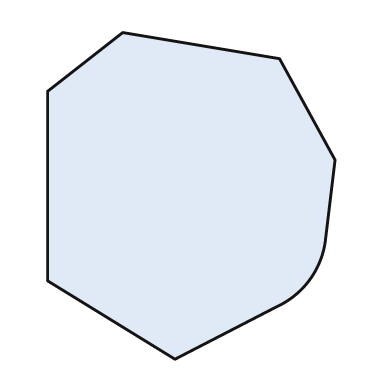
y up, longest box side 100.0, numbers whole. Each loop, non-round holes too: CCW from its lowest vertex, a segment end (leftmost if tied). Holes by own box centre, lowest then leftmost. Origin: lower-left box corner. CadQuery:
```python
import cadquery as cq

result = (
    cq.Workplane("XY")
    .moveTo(39.0, 0.0)
    .lineTo(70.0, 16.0)
    .threePointArc((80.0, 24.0), (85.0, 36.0))
    .lineTo(88.0, 61.0)
    .lineTo(71.0, 92.0)
    .lineTo(23.0, 100.0)
    .lineTo(0.0, 82.0)
    .lineTo(0.0, 24.0)
    .close()
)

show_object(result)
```